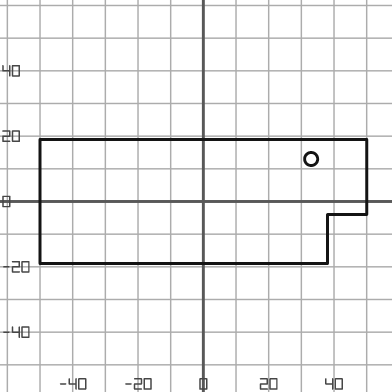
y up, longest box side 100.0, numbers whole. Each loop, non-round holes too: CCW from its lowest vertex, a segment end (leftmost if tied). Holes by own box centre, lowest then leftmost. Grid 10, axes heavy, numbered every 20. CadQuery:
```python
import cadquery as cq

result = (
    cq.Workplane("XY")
    .moveTo(-50.0, -19.0)
    .lineTo(38.0, -19.0)
    .lineTo(38.0, -4.0)
    .lineTo(50.0, -4.0)
    .lineTo(50.0, 19.0)
    .lineTo(-50.0, 19.0)
    .close()
    .moveTo(33.0, 13.0)
    .circle(2.0)
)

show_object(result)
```